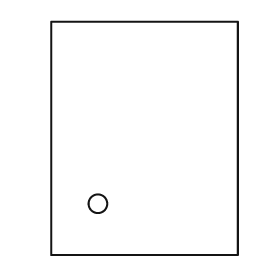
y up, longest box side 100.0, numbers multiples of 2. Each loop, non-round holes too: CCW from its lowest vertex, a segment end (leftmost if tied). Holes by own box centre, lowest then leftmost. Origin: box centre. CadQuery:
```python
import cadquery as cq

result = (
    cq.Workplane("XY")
    .moveTo(-40.0, -50.0)
    .lineTo(40.0, -50.0)
    .lineTo(40.0, 50.0)
    .lineTo(-40.0, 50.0)
    .close()
    .moveTo(-20.0, -28.0)
    .circle(4.0)
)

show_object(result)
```